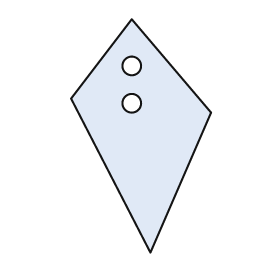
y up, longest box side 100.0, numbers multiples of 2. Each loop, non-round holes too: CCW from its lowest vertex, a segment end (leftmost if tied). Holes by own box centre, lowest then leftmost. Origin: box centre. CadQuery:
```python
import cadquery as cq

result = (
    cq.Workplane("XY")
    .moveTo(4.0, -50.0)
    .lineTo(30.0, 10.0)
    .lineTo(-4.0, 50.0)
    .lineTo(-30.0, 16.0)
    .close()
    .moveTo(-4.0, 14.0)
    .circle(4.0)
    .moveTo(-4.0, 30.0)
    .circle(4.0)
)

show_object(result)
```